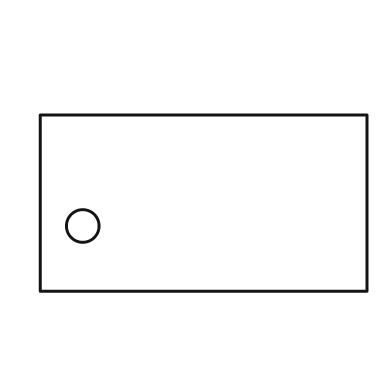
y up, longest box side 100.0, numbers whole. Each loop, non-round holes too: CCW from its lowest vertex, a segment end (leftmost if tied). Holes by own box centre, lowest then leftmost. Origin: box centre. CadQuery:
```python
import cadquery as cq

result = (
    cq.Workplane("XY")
    .moveTo(-50.0, -27.0)
    .lineTo(50.0, -27.0)
    .lineTo(50.0, 27.0)
    .lineTo(-50.0, 27.0)
    .close()
    .moveTo(-37.0, -7.0)
    .circle(5.0)
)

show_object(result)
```